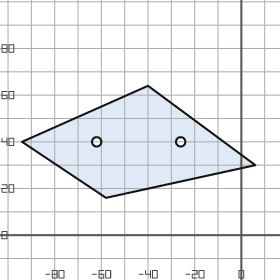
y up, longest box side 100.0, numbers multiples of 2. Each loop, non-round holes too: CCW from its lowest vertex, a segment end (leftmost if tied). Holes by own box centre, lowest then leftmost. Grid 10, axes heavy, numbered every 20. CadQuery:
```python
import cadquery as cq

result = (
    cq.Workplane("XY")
    .moveTo(-58.0, 16.0)
    .lineTo(6.0, 30.0)
    .lineTo(-40.0, 64.0)
    .lineTo(-94.0, 40.0)
    .close()
    .moveTo(-62.0, 40.0)
    .circle(2.0)
    .moveTo(-26.0, 40.0)
    .circle(2.0)
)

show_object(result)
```